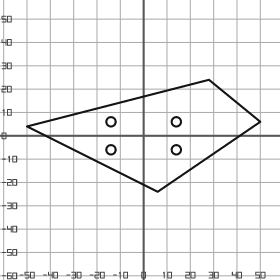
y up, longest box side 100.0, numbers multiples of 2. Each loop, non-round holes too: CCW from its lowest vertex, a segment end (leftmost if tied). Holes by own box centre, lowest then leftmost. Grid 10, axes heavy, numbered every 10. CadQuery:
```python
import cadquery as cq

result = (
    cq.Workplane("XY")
    .moveTo(6.0, -24.0)
    .lineTo(50.0, 6.0)
    .lineTo(28.0, 24.0)
    .lineTo(-50.0, 4.0)
    .close()
    .moveTo(-14.0, -6.0)
    .circle(2.0)
    .moveTo(14.0, -6.0)
    .circle(2.0)
    .moveTo(-14.0, 6.0)
    .circle(2.0)
    .moveTo(14.0, 6.0)
    .circle(2.0)
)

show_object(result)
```